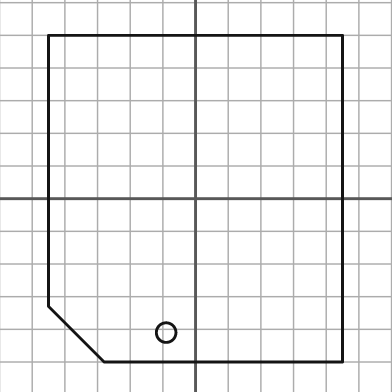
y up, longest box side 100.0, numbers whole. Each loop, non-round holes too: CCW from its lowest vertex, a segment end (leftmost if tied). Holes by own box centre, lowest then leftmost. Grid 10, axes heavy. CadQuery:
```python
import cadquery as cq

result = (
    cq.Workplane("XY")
    .moveTo(-28.0, -50.0)
    .lineTo(45.0, -50.0)
    .lineTo(45.0, 50.0)
    .lineTo(-45.0, 50.0)
    .lineTo(-45.0, -33.0)
    .close()
    .moveTo(-9.0, -41.0)
    .circle(3.0)
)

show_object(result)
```